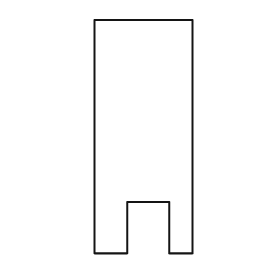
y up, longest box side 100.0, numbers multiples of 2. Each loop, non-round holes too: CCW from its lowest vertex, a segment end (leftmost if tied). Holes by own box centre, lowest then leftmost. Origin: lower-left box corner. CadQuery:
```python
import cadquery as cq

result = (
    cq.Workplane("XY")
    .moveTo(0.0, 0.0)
    .lineTo(14.0, 0.0)
    .lineTo(14.0, 22.0)
    .lineTo(32.0, 22.0)
    .lineTo(32.0, 0.0)
    .lineTo(42.0, 0.0)
    .lineTo(42.0, 100.0)
    .lineTo(0.0, 100.0)
    .close()
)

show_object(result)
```